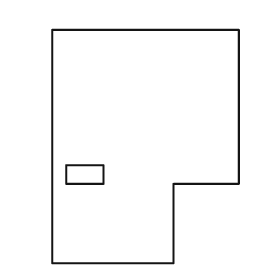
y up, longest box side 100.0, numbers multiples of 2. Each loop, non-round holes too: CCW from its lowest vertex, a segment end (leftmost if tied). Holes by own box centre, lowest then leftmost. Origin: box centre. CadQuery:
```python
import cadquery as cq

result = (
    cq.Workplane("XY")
    .moveTo(-40.0, -50.0)
    .lineTo(12.0, -50.0)
    .lineTo(12.0, -16.0)
    .lineTo(40.0, -16.0)
    .lineTo(40.0, 50.0)
    .lineTo(-40.0, 50.0)
    .close()
    .moveTo(-34.0, -16.0)
    .lineTo(-18.0, -16.0)
    .lineTo(-18.0, -8.0)
    .lineTo(-34.0, -8.0)
    .close()
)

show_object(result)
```